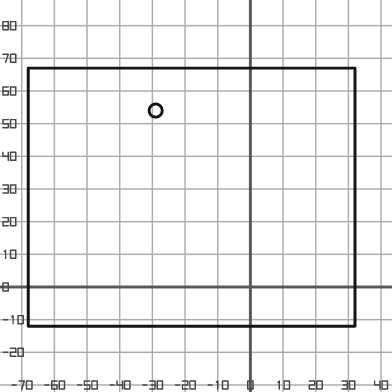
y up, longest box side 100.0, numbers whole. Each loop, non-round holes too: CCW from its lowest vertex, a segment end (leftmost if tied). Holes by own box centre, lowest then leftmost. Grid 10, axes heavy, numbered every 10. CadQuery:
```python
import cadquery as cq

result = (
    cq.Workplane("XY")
    .moveTo(-68.0, -12.0)
    .lineTo(32.0, -12.0)
    .lineTo(32.0, 67.0)
    .lineTo(-68.0, 67.0)
    .close()
    .moveTo(-29.0, 54.0)
    .circle(2.0)
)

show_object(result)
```